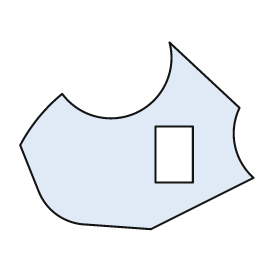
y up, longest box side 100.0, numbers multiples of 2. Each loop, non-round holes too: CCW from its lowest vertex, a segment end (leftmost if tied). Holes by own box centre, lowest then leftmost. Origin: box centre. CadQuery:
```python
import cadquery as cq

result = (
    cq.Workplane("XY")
    .moveTo(6.0, -40.0)
    .lineTo(50.0, -18.0)
    .threePointArc((42.0, -4.0), (44.0, 12.0))
    .lineTo(14.0, 40.0)
    .threePointArc((0.0, 10.0), (-32.0, 18.0))
    .threePointArc((-42.0, 8.0), (-50.0, -4.0))
    .lineTo(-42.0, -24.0)
    .threePointArc((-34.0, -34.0), (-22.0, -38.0))
    .close()
    .moveTo(8.0, -20.0)
    .lineTo(24.0, -20.0)
    .lineTo(24.0, 4.0)
    .lineTo(8.0, 4.0)
    .close()
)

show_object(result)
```